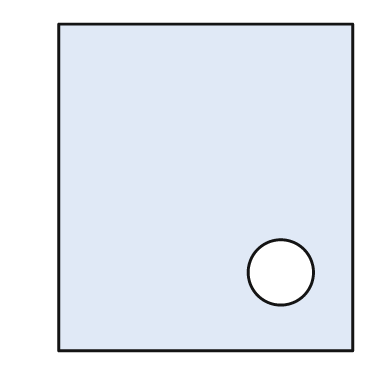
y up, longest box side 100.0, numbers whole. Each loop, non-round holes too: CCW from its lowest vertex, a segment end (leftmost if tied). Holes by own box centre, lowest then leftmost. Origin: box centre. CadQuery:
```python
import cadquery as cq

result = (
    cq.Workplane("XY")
    .moveTo(-45.0, -50.0)
    .lineTo(45.0, -50.0)
    .lineTo(45.0, 50.0)
    .lineTo(-45.0, 50.0)
    .close()
    .moveTo(23.0, -26.0)
    .circle(10.0)
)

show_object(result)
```